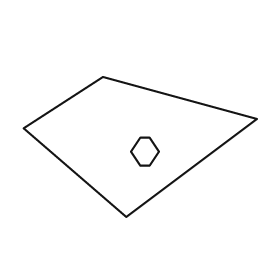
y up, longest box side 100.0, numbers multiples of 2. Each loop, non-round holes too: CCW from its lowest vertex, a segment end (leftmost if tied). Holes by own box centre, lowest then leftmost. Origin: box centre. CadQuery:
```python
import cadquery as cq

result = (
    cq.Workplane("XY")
    .moveTo(-6.0, -30.0)
    .lineTo(50.0, 12.0)
    .lineTo(-16.0, 30.0)
    .lineTo(-50.0, 8.0)
    .close()
    .moveTo(0.0, -8.0)
    .lineTo(4.0, -8.0)
    .lineTo(8.0, -2.0)
    .lineTo(4.0, 4.0)
    .lineTo(0.0, 4.0)
    .lineTo(-4.0, -2.0)
    .close()
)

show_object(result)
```